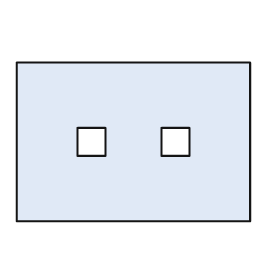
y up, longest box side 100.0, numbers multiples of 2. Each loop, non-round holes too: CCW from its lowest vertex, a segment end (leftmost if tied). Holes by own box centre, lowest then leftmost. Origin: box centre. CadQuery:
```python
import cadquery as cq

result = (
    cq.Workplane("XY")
    .moveTo(-50.0, -34.0)
    .lineTo(50.0, -34.0)
    .lineTo(50.0, 34.0)
    .lineTo(-50.0, 34.0)
    .close()
    .moveTo(-24.0, -6.0)
    .lineTo(-12.0, -6.0)
    .lineTo(-12.0, 6.0)
    .lineTo(-24.0, 6.0)
    .close()
    .moveTo(12.0, -6.0)
    .lineTo(24.0, -6.0)
    .lineTo(24.0, 6.0)
    .lineTo(12.0, 6.0)
    .close()
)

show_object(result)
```